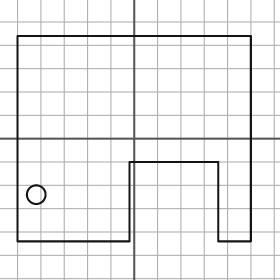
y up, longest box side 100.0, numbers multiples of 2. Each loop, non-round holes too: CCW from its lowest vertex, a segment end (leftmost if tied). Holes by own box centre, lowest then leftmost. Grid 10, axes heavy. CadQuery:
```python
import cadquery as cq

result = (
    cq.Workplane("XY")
    .moveTo(-50.0, -44.0)
    .lineTo(-2.0, -44.0)
    .lineTo(-2.0, -10.0)
    .lineTo(36.0, -10.0)
    .lineTo(36.0, -44.0)
    .lineTo(50.0, -44.0)
    .lineTo(50.0, 44.0)
    .lineTo(-50.0, 44.0)
    .close()
    .moveTo(-42.0, -24.0)
    .circle(4.0)
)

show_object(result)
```